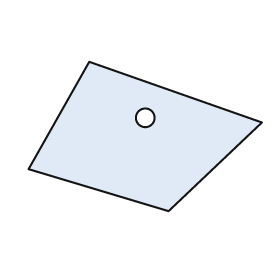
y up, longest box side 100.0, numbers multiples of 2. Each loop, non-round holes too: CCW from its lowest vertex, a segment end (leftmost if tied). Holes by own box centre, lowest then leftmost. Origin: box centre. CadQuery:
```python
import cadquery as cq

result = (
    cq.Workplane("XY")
    .moveTo(10.0, -32.0)
    .lineTo(50.0, 6.0)
    .lineTo(-24.0, 32.0)
    .lineTo(-50.0, -14.0)
    .close()
    .moveTo(0.0, 8.0)
    .circle(4.0)
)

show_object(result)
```